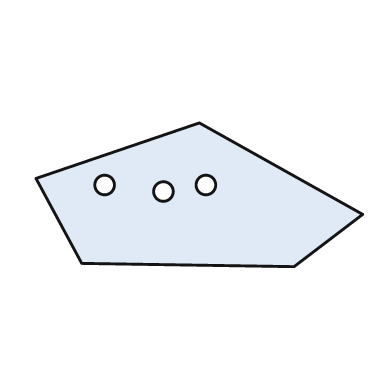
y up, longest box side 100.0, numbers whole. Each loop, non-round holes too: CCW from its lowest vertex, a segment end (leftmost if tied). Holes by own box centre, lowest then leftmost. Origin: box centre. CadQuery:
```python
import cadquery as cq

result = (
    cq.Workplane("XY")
    .moveTo(29.0, -22.0)
    .lineTo(50.0, -6.0)
    .lineTo(0.0, 22.0)
    .lineTo(-50.0, 5.0)
    .lineTo(-36.0, -21.0)
    .close()
    .moveTo(-11.0, 1.0)
    .circle(3.0)
    .moveTo(-29.0, 3.0)
    .circle(3.0)
    .moveTo(2.0, 3.0)
    .circle(3.0)
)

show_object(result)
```